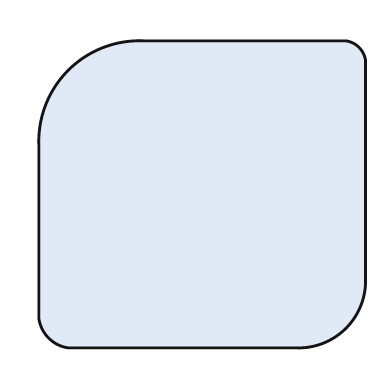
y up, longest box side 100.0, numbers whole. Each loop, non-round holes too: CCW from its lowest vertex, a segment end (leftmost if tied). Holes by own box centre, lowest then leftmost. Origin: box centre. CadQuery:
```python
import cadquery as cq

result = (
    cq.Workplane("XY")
    .moveTo(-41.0, -47.0)
    .lineTo(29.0, -47.0)
    .threePointArc((44.0, -41.0), (50.0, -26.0))
    .lineTo(50.0, 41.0)
    .threePointArc((48.0, 45.0), (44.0, 47.0))
    .lineTo(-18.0, 47.0)
    .threePointArc((-41.0, 38.0), (-50.0, 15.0))
    .lineTo(-50.0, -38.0)
    .threePointArc((-47.0, -44.0), (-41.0, -47.0))
    .close()
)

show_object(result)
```